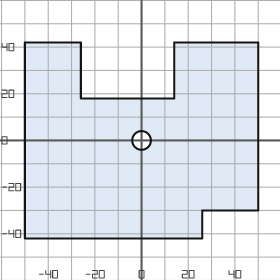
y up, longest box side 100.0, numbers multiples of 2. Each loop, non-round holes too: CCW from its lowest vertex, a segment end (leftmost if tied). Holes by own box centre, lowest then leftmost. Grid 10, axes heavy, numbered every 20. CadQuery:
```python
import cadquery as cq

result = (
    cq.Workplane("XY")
    .moveTo(-50.0, -42.0)
    .lineTo(26.0, -42.0)
    .lineTo(26.0, -30.0)
    .lineTo(50.0, -30.0)
    .lineTo(50.0, 42.0)
    .lineTo(14.0, 42.0)
    .lineTo(14.0, 18.0)
    .lineTo(-26.0, 18.0)
    .lineTo(-26.0, 42.0)
    .lineTo(-50.0, 42.0)
    .close()
    .moveTo(0.0, 0.0)
    .circle(4.0)
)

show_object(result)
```